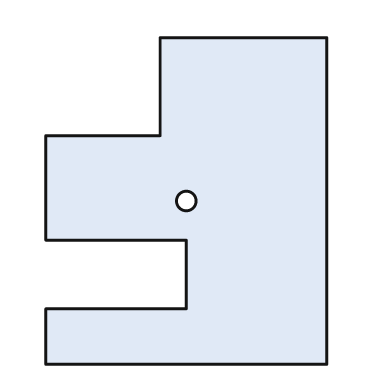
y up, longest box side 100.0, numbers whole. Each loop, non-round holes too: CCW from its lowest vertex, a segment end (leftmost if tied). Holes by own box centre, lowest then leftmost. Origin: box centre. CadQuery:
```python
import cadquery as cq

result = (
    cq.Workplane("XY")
    .moveTo(-43.0, -50.0)
    .lineTo(43.0, -50.0)
    .lineTo(43.0, 50.0)
    .lineTo(-8.0, 50.0)
    .lineTo(-8.0, 20.0)
    .lineTo(-43.0, 20.0)
    .lineTo(-43.0, -12.0)
    .lineTo(0.0, -12.0)
    .lineTo(0.0, -33.0)
    .lineTo(-43.0, -33.0)
    .close()
    .moveTo(0.0, 0.0)
    .circle(3.0)
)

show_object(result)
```